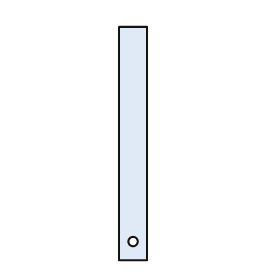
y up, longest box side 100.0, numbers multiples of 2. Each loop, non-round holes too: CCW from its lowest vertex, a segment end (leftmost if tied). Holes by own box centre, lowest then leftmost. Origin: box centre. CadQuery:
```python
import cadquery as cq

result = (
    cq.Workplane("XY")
    .moveTo(-6.0, -50.0)
    .lineTo(6.0, -50.0)
    .lineTo(6.0, 50.0)
    .lineTo(-6.0, 50.0)
    .close()
    .moveTo(0.0, -42.0)
    .circle(2.0)
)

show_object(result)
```